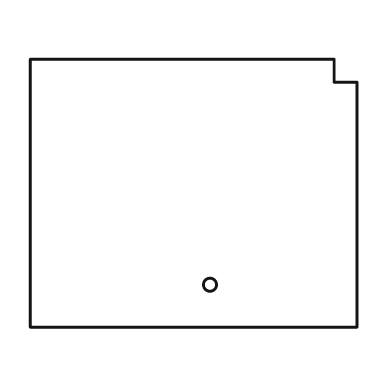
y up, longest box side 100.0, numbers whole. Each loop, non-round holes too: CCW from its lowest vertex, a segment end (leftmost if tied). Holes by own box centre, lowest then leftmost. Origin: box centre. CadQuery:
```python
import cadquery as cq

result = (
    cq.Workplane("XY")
    .moveTo(-50.0, -41.0)
    .lineTo(50.0, -41.0)
    .lineTo(50.0, 34.0)
    .lineTo(43.0, 34.0)
    .lineTo(43.0, 41.0)
    .lineTo(-50.0, 41.0)
    .close()
    .moveTo(5.0, -28.0)
    .circle(2.0)
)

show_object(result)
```